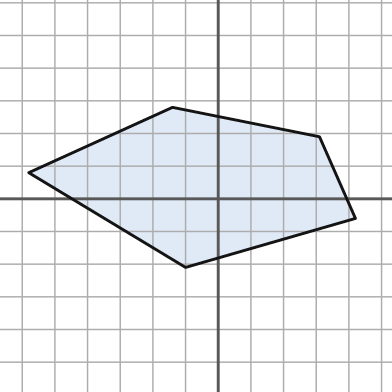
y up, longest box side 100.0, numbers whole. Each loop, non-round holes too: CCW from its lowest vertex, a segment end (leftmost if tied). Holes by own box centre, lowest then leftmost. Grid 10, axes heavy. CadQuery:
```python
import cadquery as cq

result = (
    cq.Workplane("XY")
    .moveTo(-10.0, -21.0)
    .lineTo(42.0, -6.0)
    .lineTo(31.0, 19.0)
    .lineTo(-14.0, 28.0)
    .lineTo(-58.0, 8.0)
    .close()
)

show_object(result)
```